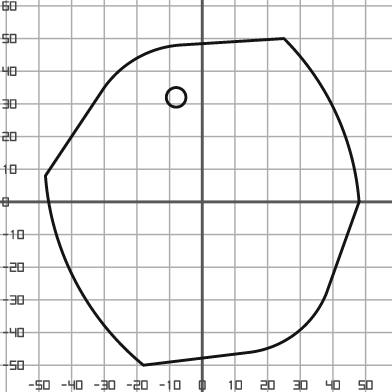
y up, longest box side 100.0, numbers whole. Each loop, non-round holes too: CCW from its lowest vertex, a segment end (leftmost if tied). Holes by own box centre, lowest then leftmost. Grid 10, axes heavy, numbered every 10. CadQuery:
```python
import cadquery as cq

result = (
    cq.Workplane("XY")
    .moveTo(-18.0, -50.0)
    .lineTo(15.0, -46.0)
    .threePointArc((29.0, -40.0), (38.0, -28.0))
    .lineTo(48.0, 0.0)
    .threePointArc((41.0, 27.0), (25.0, 50.0))
    .lineTo(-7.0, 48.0)
    .threePointArc((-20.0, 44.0), (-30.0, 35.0))
    .lineTo(-48.0, 8.0)
    .threePointArc((-39.0, -24.0), (-18.0, -50.0))
    .close()
    .moveTo(-8.0, 32.0)
    .circle(3.0)
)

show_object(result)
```